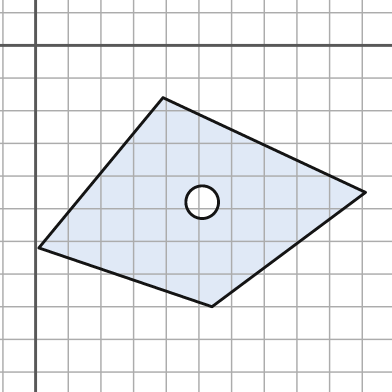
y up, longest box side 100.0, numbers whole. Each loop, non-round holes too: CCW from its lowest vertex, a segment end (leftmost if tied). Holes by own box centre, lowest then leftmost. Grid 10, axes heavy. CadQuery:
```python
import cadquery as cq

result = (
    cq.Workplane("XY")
    .moveTo(54.0, -80.0)
    .lineTo(101.0, -45.0)
    .lineTo(39.0, -16.0)
    .lineTo(1.0, -62.0)
    .close()
    .moveTo(51.0, -48.0)
    .circle(5.0)
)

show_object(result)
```